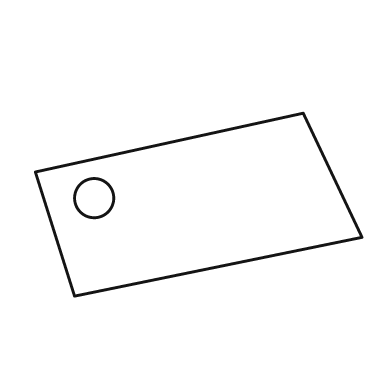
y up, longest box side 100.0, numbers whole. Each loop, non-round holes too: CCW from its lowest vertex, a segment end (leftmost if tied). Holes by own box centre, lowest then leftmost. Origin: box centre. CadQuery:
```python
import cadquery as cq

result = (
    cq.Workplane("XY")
    .moveTo(-38.0, -28.0)
    .lineTo(50.0, -10.0)
    .lineTo(32.0, 28.0)
    .lineTo(-50.0, 10.0)
    .close()
    .moveTo(-32.0, 2.0)
    .circle(6.0)
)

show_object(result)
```